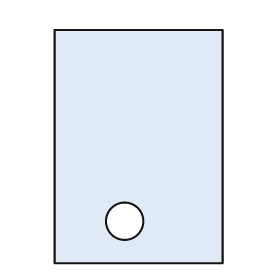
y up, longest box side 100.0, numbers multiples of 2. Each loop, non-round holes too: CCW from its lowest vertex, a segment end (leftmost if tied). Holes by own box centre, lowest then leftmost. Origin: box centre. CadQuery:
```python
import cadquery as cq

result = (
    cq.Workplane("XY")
    .moveTo(-36.0, -50.0)
    .lineTo(36.0, -50.0)
    .lineTo(36.0, 50.0)
    .lineTo(-36.0, 50.0)
    .close()
    .moveTo(-6.0, -32.0)
    .circle(8.0)
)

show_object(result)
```